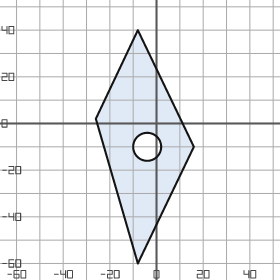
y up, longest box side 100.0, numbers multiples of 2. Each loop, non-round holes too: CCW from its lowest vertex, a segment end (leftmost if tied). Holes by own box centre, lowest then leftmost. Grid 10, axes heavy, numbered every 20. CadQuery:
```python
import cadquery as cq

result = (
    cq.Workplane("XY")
    .moveTo(-8.0, -60.0)
    .lineTo(16.0, -10.0)
    .lineTo(-8.0, 40.0)
    .lineTo(-26.0, 2.0)
    .close()
    .moveTo(-4.0, -10.0)
    .circle(6.0)
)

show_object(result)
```